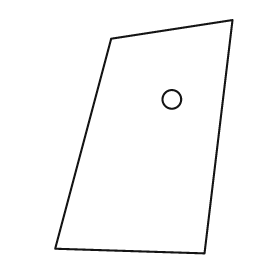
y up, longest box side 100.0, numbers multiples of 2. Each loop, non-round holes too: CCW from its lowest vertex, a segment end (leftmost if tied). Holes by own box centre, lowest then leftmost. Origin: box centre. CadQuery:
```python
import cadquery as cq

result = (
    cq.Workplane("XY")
    .moveTo(26.0, -50.0)
    .lineTo(38.0, 50.0)
    .lineTo(-14.0, 42.0)
    .lineTo(-38.0, -48.0)
    .close()
    .moveTo(12.0, 16.0)
    .circle(4.0)
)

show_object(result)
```